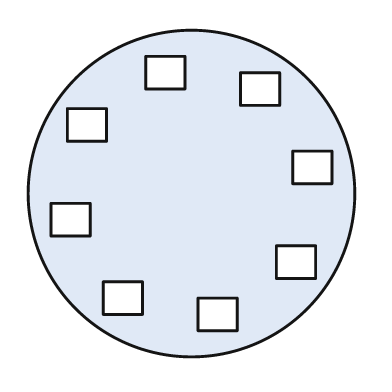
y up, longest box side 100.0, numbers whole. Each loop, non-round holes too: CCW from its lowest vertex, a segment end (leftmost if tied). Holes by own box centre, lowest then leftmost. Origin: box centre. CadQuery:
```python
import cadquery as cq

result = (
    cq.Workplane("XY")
    .moveTo(0.0, 0.0)
    .circle(50.0)
    .moveTo(2.0, -42.0)
    .lineTo(14.0, -42.0)
    .lineTo(14.0, -32.0)
    .lineTo(2.0, -32.0)
    .close()
    .moveTo(-27.0, -37.0)
    .lineTo(-15.0, -37.0)
    .lineTo(-15.0, -27.0)
    .lineTo(-27.0, -27.0)
    .close()
    .moveTo(26.0, -26.0)
    .lineTo(38.0, -26.0)
    .lineTo(38.0, -16.0)
    .lineTo(26.0, -16.0)
    .close()
    .moveTo(-43.0, -13.0)
    .lineTo(-31.0, -13.0)
    .lineTo(-31.0, -3.0)
    .lineTo(-43.0, -3.0)
    .close()
    .moveTo(31.0, 3.0)
    .lineTo(43.0, 3.0)
    .lineTo(43.0, 13.0)
    .lineTo(31.0, 13.0)
    .close()
    .moveTo(-38.0, 16.0)
    .lineTo(-26.0, 16.0)
    .lineTo(-26.0, 26.0)
    .lineTo(-38.0, 26.0)
    .close()
    .moveTo(15.0, 27.0)
    .lineTo(27.0, 27.0)
    .lineTo(27.0, 37.0)
    .lineTo(15.0, 37.0)
    .close()
    .moveTo(-14.0, 32.0)
    .lineTo(-2.0, 32.0)
    .lineTo(-2.0, 42.0)
    .lineTo(-14.0, 42.0)
    .close()
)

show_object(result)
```